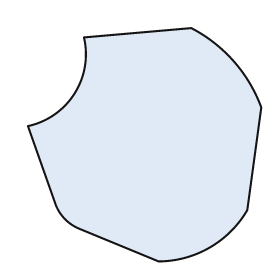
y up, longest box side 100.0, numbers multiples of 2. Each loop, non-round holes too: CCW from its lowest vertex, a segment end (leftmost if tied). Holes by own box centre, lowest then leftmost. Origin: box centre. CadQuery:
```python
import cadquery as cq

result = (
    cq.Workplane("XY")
    .moveTo(6.0, -50.0)
    .threePointArc((28.0, -44.0), (44.0, -28.0))
    .lineTo(50.0, 16.0)
    .threePointArc((38.0, 36.0), (20.0, 50.0))
    .lineTo(-26.0, 46.0)
    .threePointArc((-30.0, 22.0), (-50.0, 8.0))
    .lineTo(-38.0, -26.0)
    .threePointArc((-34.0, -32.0), (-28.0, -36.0))
    .close()
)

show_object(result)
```